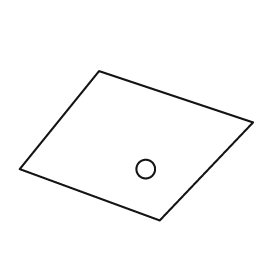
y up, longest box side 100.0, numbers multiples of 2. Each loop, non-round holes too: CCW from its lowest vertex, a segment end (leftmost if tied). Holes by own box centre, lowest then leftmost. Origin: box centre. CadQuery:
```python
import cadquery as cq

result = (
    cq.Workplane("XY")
    .moveTo(10.0, -32.0)
    .lineTo(50.0, 10.0)
    .lineTo(-16.0, 32.0)
    .lineTo(-50.0, -10.0)
    .close()
    .moveTo(4.0, -10.0)
    .circle(4.0)
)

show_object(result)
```